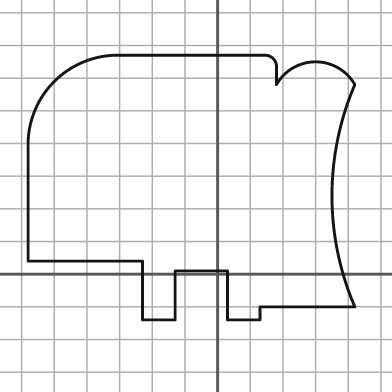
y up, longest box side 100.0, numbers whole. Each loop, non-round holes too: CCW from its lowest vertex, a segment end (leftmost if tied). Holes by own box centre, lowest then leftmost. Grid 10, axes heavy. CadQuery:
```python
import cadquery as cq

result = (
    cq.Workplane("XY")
    .moveTo(-23.0, -14.0)
    .lineTo(-13.0, -14.0)
    .lineTo(-13.0, 1.0)
    .lineTo(3.0, 1.0)
    .lineTo(3.0, -14.0)
    .lineTo(13.0, -14.0)
    .lineTo(13.0, -10.0)
    .lineTo(42.0, -10.0)
    .threePointArc((35.0, 24.0), (42.0, 58.0))
    .threePointArc((30.0, 65.0), (18.0, 58.0))
    .lineTo(18.0, 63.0)
    .threePointArc((17.0, 66.0), (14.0, 67.0))
    .lineTo(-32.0, 67.0)
    .threePointArc((-50.0, 59.0), (-58.0, 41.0))
    .lineTo(-58.0, 4.0)
    .lineTo(-23.0, 4.0)
    .close()
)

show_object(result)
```